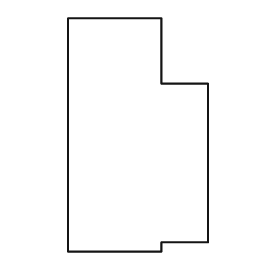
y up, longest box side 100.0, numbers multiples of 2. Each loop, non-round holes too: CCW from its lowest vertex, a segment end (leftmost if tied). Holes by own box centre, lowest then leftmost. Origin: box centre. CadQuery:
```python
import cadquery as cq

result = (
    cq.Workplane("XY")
    .moveTo(-30.0, -50.0)
    .lineTo(10.0, -50.0)
    .lineTo(10.0, -46.0)
    .lineTo(30.0, -46.0)
    .lineTo(30.0, 22.0)
    .lineTo(10.0, 22.0)
    .lineTo(10.0, 50.0)
    .lineTo(-30.0, 50.0)
    .close()
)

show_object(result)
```